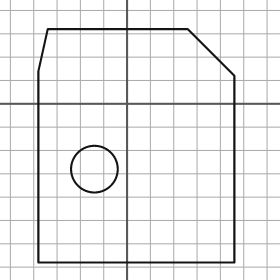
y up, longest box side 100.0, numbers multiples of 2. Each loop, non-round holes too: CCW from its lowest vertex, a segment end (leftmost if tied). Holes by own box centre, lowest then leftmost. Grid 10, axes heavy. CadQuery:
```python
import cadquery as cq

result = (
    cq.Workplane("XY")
    .moveTo(-38.0, -68.0)
    .lineTo(46.0, -68.0)
    .lineTo(46.0, 12.0)
    .lineTo(26.0, 32.0)
    .lineTo(-34.0, 32.0)
    .lineTo(-38.0, 14.0)
    .close()
    .moveTo(-14.0, -28.0)
    .circle(10.0)
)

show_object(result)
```